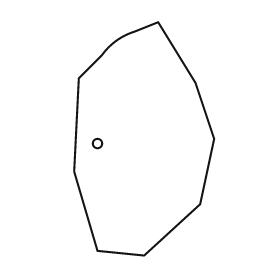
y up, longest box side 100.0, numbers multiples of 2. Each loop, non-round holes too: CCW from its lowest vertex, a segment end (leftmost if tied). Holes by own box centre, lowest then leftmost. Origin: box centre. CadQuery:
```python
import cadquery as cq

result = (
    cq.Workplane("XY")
    .moveTo(0.0, -50.0)
    .lineTo(24.0, -28.0)
    .lineTo(30.0, 0.0)
    .lineTo(22.0, 24.0)
    .lineTo(6.0, 50.0)
    .lineTo(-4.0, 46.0)
    .threePointArc((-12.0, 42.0), (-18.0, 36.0))
    .lineTo(-28.0, 26.0)
    .lineTo(-30.0, -14.0)
    .lineTo(-20.0, -48.0)
    .close()
    .moveTo(-20.0, -2.0)
    .circle(2.0)
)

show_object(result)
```